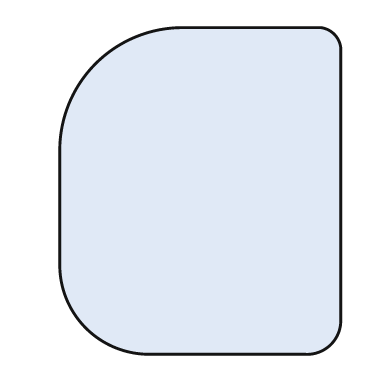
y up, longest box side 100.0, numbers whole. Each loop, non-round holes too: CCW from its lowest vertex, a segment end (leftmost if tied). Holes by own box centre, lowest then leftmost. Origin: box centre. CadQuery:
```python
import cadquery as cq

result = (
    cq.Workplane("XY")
    .moveTo(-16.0, -50.0)
    .lineTo(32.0, -50.0)
    .threePointArc((40.0, -47.0), (43.0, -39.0))
    .lineTo(43.0, 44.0)
    .threePointArc((41.0, 48.0), (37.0, 50.0))
    .lineTo(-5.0, 50.0)
    .threePointArc((-32.0, 39.0), (-43.0, 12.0))
    .lineTo(-43.0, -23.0)
    .threePointArc((-35.0, -42.0), (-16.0, -50.0))
    .close()
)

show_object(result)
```